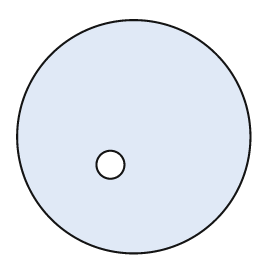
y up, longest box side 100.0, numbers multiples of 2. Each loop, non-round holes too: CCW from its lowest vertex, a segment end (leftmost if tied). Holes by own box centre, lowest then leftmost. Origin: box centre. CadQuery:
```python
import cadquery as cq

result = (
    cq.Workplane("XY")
    .moveTo(0.0, 0.0)
    .circle(50.0)
    .moveTo(-10.0, -12.0)
    .circle(6.0)
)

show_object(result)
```